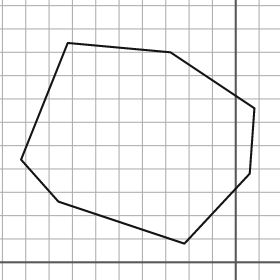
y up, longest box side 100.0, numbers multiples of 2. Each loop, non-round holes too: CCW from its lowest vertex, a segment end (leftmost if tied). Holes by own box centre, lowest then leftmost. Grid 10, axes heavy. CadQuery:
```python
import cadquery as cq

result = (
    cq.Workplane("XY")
    .moveTo(-22.0, 8.0)
    .lineTo(6.0, 38.0)
    .lineTo(8.0, 66.0)
    .lineTo(-28.0, 90.0)
    .lineTo(-72.0, 94.0)
    .lineTo(-92.0, 44.0)
    .lineTo(-76.0, 26.0)
    .close()
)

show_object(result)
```